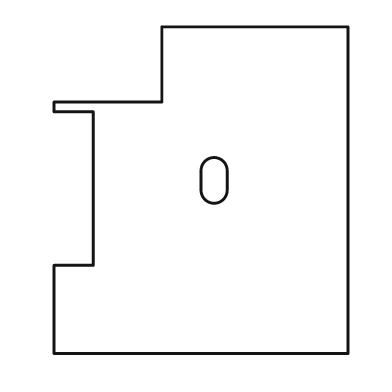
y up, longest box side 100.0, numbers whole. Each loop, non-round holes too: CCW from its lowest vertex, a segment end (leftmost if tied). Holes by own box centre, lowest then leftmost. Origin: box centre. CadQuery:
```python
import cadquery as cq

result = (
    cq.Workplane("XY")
    .moveTo(-45.0, -50.0)
    .lineTo(45.0, -50.0)
    .lineTo(45.0, 50.0)
    .lineTo(-12.0, 50.0)
    .lineTo(-12.0, 27.0)
    .lineTo(-45.0, 27.0)
    .lineTo(-45.0, 24.0)
    .lineTo(-33.0, 24.0)
    .lineTo(-33.0, -23.0)
    .lineTo(-45.0, -23.0)
    .close()
    .moveTo(0.0, 0.0)
    .threePointArc((4.0, -4.0), (8.0, 0.0))
    .lineTo(8.0, 6.0)
    .threePointArc((4.0, 10.0), (0.0, 6.0))
    .close()
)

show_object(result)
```